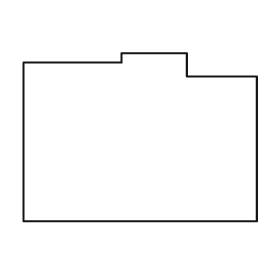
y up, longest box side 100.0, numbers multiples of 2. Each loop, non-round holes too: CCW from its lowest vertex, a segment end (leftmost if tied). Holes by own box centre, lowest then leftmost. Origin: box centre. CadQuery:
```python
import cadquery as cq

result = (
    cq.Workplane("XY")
    .moveTo(-50.0, -36.0)
    .lineTo(50.0, -36.0)
    .lineTo(50.0, 26.0)
    .lineTo(20.0, 26.0)
    .lineTo(20.0, 36.0)
    .lineTo(-8.0, 36.0)
    .lineTo(-8.0, 32.0)
    .lineTo(-50.0, 32.0)
    .close()
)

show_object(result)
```